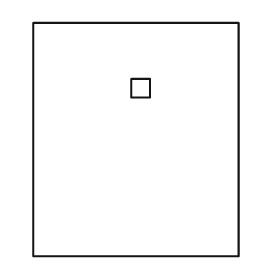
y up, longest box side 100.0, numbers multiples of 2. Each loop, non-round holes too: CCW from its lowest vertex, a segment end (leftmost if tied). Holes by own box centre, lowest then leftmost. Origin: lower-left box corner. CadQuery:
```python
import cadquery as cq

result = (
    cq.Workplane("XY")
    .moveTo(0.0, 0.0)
    .lineTo(88.0, 0.0)
    .lineTo(88.0, 100.0)
    .lineTo(0.0, 100.0)
    .close()
    .moveTo(42.0, 68.0)
    .lineTo(50.0, 68.0)
    .lineTo(50.0, 76.0)
    .lineTo(42.0, 76.0)
    .close()
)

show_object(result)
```